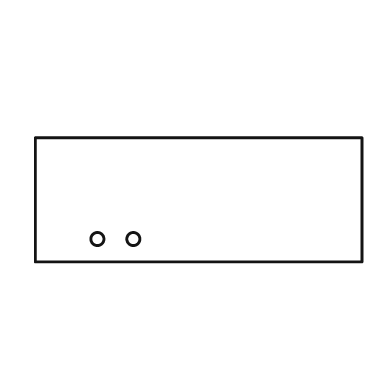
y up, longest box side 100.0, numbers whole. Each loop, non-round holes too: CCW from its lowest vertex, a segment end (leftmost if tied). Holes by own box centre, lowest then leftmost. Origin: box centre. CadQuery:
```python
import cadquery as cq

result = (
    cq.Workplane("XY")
    .moveTo(-50.0, -19.0)
    .lineTo(50.0, -19.0)
    .lineTo(50.0, 19.0)
    .lineTo(-50.0, 19.0)
    .close()
    .moveTo(-31.0, -12.0)
    .circle(2.0)
    .moveTo(-20.0, -12.0)
    .circle(2.0)
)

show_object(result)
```